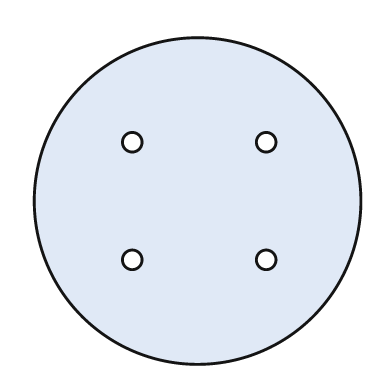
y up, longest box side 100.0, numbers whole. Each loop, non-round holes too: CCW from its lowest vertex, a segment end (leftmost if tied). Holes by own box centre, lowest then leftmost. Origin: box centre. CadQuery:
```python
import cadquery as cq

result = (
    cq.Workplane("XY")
    .moveTo(0.0, 0.0)
    .circle(50.0)
    .moveTo(-20.0, -18.0)
    .circle(3.0)
    .moveTo(21.0, -18.0)
    .circle(3.0)
    .moveTo(-20.0, 18.0)
    .circle(3.0)
    .moveTo(21.0, 18.0)
    .circle(3.0)
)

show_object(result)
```